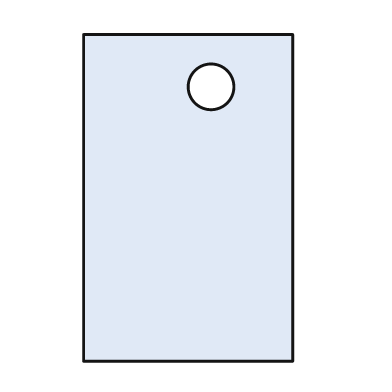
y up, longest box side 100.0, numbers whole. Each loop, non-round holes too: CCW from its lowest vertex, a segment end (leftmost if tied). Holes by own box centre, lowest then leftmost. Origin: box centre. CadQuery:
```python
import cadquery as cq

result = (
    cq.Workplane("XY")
    .moveTo(-32.0, -50.0)
    .lineTo(32.0, -50.0)
    .lineTo(32.0, 50.0)
    .lineTo(-32.0, 50.0)
    .close()
    .moveTo(7.0, 34.0)
    .circle(7.0)
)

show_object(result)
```